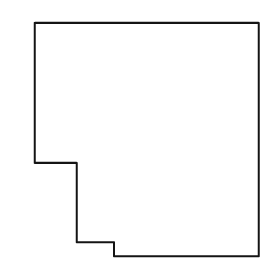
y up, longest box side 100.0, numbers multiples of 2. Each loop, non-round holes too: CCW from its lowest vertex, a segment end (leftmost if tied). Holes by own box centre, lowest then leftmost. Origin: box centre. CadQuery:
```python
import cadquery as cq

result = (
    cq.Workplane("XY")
    .moveTo(-14.0, -50.0)
    .lineTo(48.0, -50.0)
    .lineTo(48.0, 50.0)
    .lineTo(-48.0, 50.0)
    .lineTo(-48.0, -10.0)
    .lineTo(-30.0, -10.0)
    .lineTo(-30.0, -44.0)
    .lineTo(-14.0, -44.0)
    .close()
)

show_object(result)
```